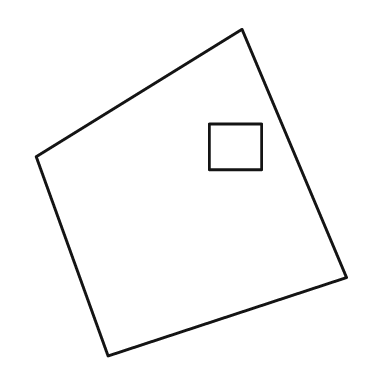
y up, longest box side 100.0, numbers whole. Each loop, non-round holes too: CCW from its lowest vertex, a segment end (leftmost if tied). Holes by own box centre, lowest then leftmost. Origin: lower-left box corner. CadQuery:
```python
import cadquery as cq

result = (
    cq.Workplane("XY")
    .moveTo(22.0, 0.0)
    .lineTo(95.0, 24.0)
    .lineTo(63.0, 100.0)
    .lineTo(0.0, 61.0)
    .close()
    .moveTo(53.0, 57.0)
    .lineTo(69.0, 57.0)
    .lineTo(69.0, 71.0)
    .lineTo(53.0, 71.0)
    .close()
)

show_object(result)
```